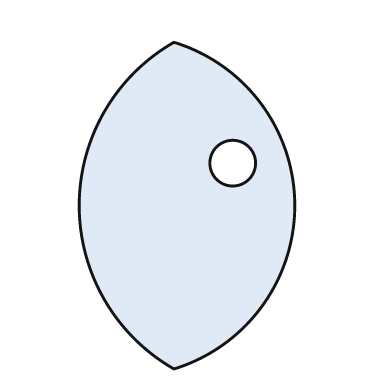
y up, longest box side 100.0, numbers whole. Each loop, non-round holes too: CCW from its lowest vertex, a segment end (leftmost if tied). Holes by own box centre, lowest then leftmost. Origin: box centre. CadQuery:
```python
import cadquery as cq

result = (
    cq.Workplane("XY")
    .moveTo(-4.0, -50.0)
    .threePointArc((33.0, 0.0), (-4.0, 50.0))
    .threePointArc((-33.0, 0.0), (-4.0, -50.0))
    .close()
    .moveTo(14.0, 13.0)
    .circle(7.0)
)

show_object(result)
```